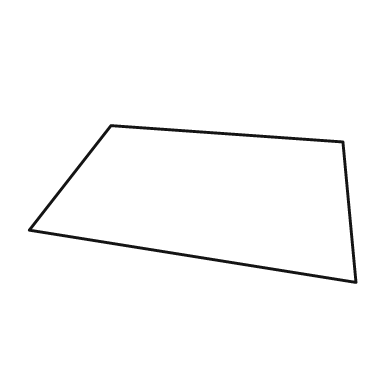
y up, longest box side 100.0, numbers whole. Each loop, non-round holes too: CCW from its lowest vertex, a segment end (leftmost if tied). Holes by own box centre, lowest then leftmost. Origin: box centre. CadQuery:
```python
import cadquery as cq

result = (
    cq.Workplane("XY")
    .moveTo(50.0, -24.0)
    .lineTo(46.0, 19.0)
    .lineTo(-25.0, 24.0)
    .lineTo(-50.0, -8.0)
    .close()
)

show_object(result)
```